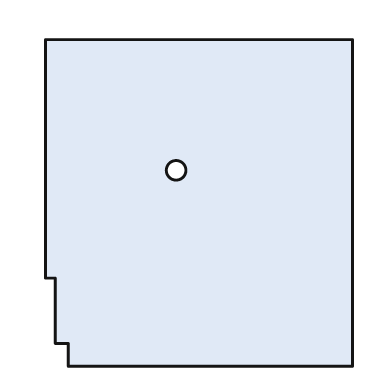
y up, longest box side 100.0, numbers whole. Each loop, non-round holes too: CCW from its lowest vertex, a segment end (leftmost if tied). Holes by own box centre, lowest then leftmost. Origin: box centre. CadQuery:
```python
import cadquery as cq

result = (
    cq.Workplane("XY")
    .moveTo(-40.0, -50.0)
    .lineTo(47.0, -50.0)
    .lineTo(47.0, 50.0)
    .lineTo(-47.0, 50.0)
    .lineTo(-47.0, -23.0)
    .lineTo(-44.0, -23.0)
    .lineTo(-44.0, -43.0)
    .lineTo(-40.0, -43.0)
    .close()
    .moveTo(-7.0, 10.0)
    .circle(3.0)
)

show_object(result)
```